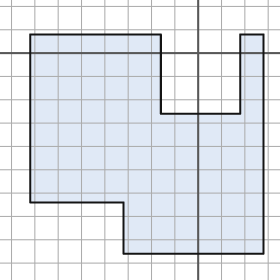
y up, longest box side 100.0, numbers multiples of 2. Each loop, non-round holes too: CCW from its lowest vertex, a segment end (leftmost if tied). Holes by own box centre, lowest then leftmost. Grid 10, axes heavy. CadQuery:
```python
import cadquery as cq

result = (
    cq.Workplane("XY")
    .moveTo(-32.0, -86.0)
    .lineTo(28.0, -86.0)
    .lineTo(28.0, 8.0)
    .lineTo(18.0, 8.0)
    .lineTo(18.0, -26.0)
    .lineTo(-16.0, -26.0)
    .lineTo(-16.0, 8.0)
    .lineTo(-72.0, 8.0)
    .lineTo(-72.0, -64.0)
    .lineTo(-32.0, -64.0)
    .close()
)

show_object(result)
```